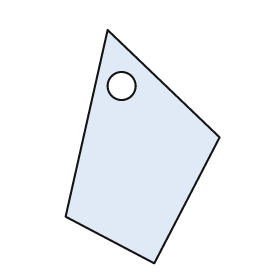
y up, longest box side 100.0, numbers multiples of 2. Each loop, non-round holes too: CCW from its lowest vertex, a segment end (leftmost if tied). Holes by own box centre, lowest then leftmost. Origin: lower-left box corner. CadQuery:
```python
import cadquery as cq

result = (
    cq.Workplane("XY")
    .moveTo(38.0, 0.0)
    .lineTo(66.0, 54.0)
    .lineTo(18.0, 100.0)
    .lineTo(0.0, 20.0)
    .close()
    .moveTo(24.0, 76.0)
    .circle(6.0)
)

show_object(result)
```